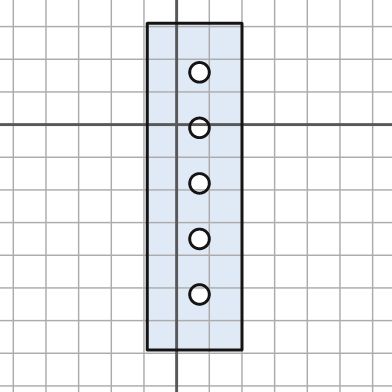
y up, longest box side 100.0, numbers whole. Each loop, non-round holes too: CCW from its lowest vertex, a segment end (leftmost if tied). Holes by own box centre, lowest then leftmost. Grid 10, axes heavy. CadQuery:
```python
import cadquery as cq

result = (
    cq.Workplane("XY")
    .moveTo(-9.0, -69.0)
    .lineTo(20.0, -69.0)
    .lineTo(20.0, 31.0)
    .lineTo(-9.0, 31.0)
    .close()
    .moveTo(7.0, -52.0)
    .circle(3.0)
    .moveTo(7.0, -35.0)
    .circle(3.0)
    .moveTo(7.0, -18.0)
    .circle(3.0)
    .moveTo(7.0, -1.0)
    .circle(3.0)
    .moveTo(7.0, 16.0)
    .circle(3.0)
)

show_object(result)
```